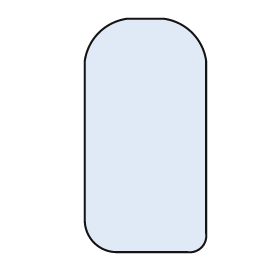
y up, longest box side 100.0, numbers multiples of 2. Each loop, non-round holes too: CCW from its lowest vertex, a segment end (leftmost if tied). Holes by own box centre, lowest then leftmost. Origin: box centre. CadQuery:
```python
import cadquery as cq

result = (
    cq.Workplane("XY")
    .moveTo(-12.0, -50.0)
    .lineTo(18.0, -50.0)
    .threePointArc((24.0, -48.0), (26.0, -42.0))
    .lineTo(26.0, 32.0)
    .threePointArc((20.0, 44.0), (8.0, 50.0))
    .lineTo(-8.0, 50.0)
    .threePointArc((-20.0, 44.0), (-26.0, 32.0))
    .lineTo(-26.0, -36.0)
    .threePointArc((-22.0, -46.0), (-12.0, -50.0))
    .close()
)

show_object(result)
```